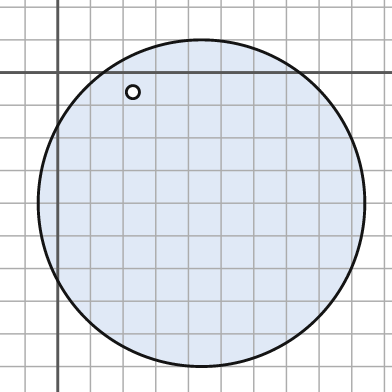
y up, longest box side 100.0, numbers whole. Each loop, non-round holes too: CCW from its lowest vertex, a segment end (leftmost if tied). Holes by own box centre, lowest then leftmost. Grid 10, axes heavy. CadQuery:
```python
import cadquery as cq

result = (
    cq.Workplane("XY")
    .moveTo(44.0, -40.0)
    .circle(50.0)
    .moveTo(23.0, -6.0)
    .circle(2.0)
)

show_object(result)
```